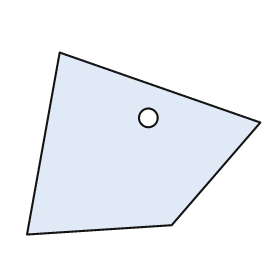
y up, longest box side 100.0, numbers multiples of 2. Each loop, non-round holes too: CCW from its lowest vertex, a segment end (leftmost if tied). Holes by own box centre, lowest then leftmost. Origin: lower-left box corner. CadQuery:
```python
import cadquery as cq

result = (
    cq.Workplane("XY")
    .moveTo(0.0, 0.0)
    .lineTo(62.0, 4.0)
    .lineTo(100.0, 48.0)
    .lineTo(14.0, 78.0)
    .close()
    .moveTo(52.0, 50.0)
    .circle(4.0)
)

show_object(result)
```